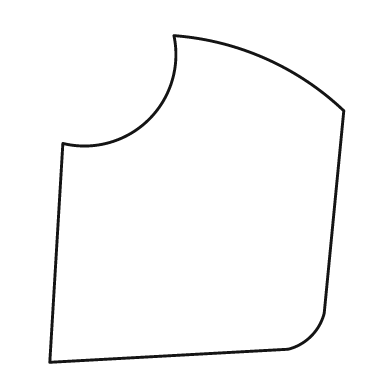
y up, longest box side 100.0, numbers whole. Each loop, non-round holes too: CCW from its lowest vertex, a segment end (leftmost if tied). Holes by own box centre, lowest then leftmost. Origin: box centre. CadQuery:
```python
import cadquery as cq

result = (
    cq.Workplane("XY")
    .moveTo(-45.0, -50.0)
    .lineTo(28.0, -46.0)
    .threePointArc((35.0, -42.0), (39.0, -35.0))
    .lineTo(45.0, 27.0)
    .threePointArc((21.0, 43.0), (-7.0, 50.0))
    .threePointArc((-15.0, 24.0), (-41.0, 17.0))
    .close()
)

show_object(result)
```